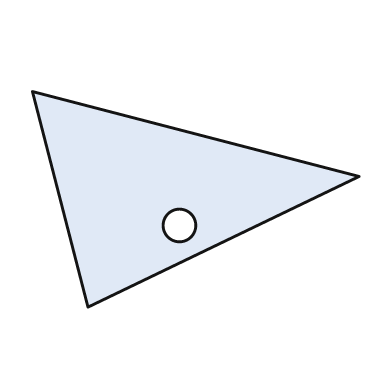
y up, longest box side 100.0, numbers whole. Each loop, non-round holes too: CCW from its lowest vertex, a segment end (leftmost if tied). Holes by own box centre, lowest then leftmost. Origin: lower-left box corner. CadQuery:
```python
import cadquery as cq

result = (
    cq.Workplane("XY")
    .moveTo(17.0, 0.0)
    .lineTo(100.0, 40.0)
    .lineTo(0.0, 66.0)
    .close()
    .moveTo(45.0, 25.0)
    .circle(5.0)
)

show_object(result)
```